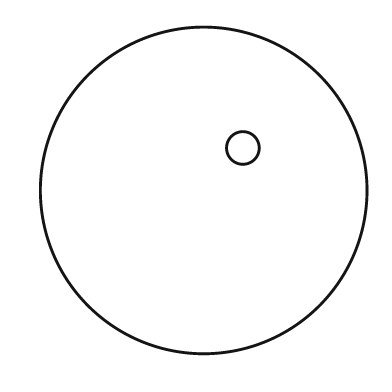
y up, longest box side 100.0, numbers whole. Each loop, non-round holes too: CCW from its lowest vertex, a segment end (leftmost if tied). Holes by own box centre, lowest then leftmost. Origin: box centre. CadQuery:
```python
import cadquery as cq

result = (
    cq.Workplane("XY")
    .moveTo(0.0, 0.0)
    .circle(50.0)
    .moveTo(12.0, 13.0)
    .circle(5.0)
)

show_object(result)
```